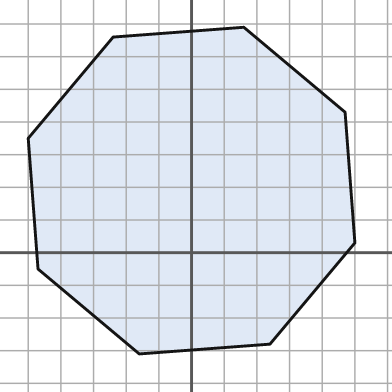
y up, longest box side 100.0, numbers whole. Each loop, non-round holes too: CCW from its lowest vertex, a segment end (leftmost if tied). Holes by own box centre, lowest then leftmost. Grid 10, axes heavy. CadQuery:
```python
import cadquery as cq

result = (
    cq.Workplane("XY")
    .moveTo(-16.0, -31.0)
    .lineTo(24.0, -28.0)
    .lineTo(50.0, 3.0)
    .lineTo(47.0, 43.0)
    .lineTo(16.0, 69.0)
    .lineTo(-24.0, 66.0)
    .lineTo(-50.0, 35.0)
    .lineTo(-47.0, -5.0)
    .close()
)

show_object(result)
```